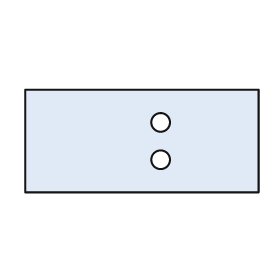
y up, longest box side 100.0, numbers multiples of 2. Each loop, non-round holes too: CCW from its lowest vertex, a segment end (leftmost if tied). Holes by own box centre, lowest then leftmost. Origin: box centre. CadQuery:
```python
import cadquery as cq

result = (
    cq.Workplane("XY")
    .moveTo(-50.0, -22.0)
    .lineTo(50.0, -22.0)
    .lineTo(50.0, 22.0)
    .lineTo(-50.0, 22.0)
    .close()
    .moveTo(8.0, -8.0)
    .circle(4.0)
    .moveTo(8.0, 8.0)
    .circle(4.0)
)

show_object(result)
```